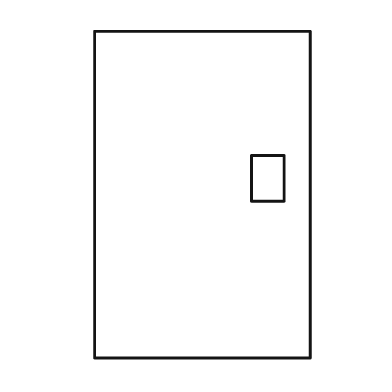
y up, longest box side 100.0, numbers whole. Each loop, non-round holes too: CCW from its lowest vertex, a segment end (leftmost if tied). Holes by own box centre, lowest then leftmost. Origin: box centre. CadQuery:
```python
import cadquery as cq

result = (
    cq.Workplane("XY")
    .moveTo(-33.0, -50.0)
    .lineTo(33.0, -50.0)
    .lineTo(33.0, 50.0)
    .lineTo(-33.0, 50.0)
    .close()
    .moveTo(15.0, -2.0)
    .lineTo(25.0, -2.0)
    .lineTo(25.0, 12.0)
    .lineTo(15.0, 12.0)
    .close()
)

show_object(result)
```